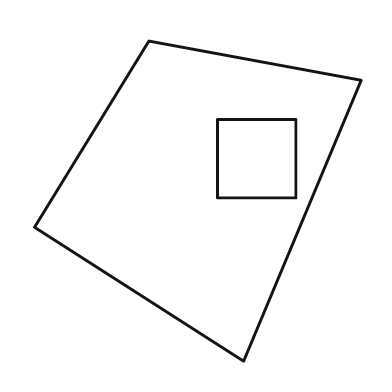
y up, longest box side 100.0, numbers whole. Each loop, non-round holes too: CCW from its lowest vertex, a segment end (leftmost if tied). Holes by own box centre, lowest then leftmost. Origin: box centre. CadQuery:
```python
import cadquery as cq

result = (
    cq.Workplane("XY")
    .moveTo(14.0, -49.0)
    .lineTo(50.0, 37.0)
    .lineTo(-15.0, 49.0)
    .lineTo(-50.0, -8.0)
    .close()
    .moveTo(6.0, 1.0)
    .lineTo(30.0, 1.0)
    .lineTo(30.0, 25.0)
    .lineTo(6.0, 25.0)
    .close()
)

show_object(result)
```